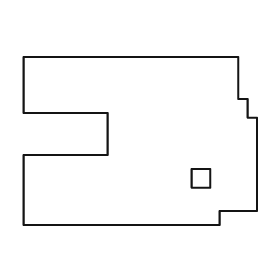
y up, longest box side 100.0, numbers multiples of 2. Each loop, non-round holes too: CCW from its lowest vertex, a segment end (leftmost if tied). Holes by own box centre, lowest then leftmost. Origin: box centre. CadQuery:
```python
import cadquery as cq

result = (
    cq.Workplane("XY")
    .moveTo(-50.0, -36.0)
    .lineTo(34.0, -36.0)
    .lineTo(34.0, -30.0)
    .lineTo(50.0, -30.0)
    .lineTo(50.0, 10.0)
    .lineTo(46.0, 10.0)
    .lineTo(46.0, 18.0)
    .lineTo(42.0, 18.0)
    .lineTo(42.0, 36.0)
    .lineTo(-50.0, 36.0)
    .lineTo(-50.0, 12.0)
    .lineTo(-14.0, 12.0)
    .lineTo(-14.0, -6.0)
    .lineTo(-50.0, -6.0)
    .close()
    .moveTo(22.0, -20.0)
    .lineTo(30.0, -20.0)
    .lineTo(30.0, -12.0)
    .lineTo(22.0, -12.0)
    .close()
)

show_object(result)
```